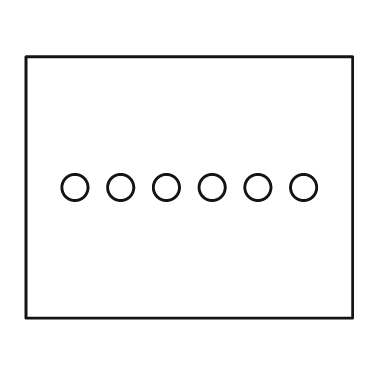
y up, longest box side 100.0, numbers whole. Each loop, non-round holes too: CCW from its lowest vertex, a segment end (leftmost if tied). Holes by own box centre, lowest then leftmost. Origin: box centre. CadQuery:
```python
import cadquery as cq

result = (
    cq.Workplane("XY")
    .moveTo(-50.0, -40.0)
    .lineTo(50.0, -40.0)
    .lineTo(50.0, 40.0)
    .lineTo(-50.0, 40.0)
    .close()
    .moveTo(-35.0, 0.0)
    .circle(4.0)
    .moveTo(-21.0, 0.0)
    .circle(4.0)
    .moveTo(-7.0, 0.0)
    .circle(4.0)
    .moveTo(7.0, 0.0)
    .circle(4.0)
    .moveTo(21.0, 0.0)
    .circle(4.0)
    .moveTo(35.0, 0.0)
    .circle(4.0)
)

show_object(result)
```